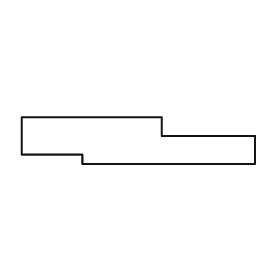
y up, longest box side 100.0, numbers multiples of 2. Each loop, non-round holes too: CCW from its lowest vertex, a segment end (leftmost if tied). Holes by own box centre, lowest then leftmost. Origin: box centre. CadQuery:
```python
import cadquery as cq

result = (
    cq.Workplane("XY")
    .moveTo(-24.0, -10.0)
    .lineTo(50.0, -10.0)
    .lineTo(50.0, 2.0)
    .lineTo(10.0, 2.0)
    .lineTo(10.0, 10.0)
    .lineTo(-50.0, 10.0)
    .lineTo(-50.0, -6.0)
    .lineTo(-24.0, -6.0)
    .close()
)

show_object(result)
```